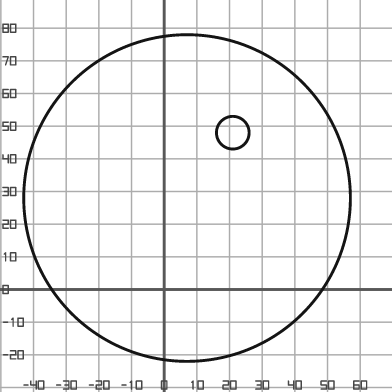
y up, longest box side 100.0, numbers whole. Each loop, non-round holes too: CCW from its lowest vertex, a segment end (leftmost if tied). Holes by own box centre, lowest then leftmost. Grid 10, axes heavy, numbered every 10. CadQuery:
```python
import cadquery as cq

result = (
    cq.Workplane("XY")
    .moveTo(7.0, 28.0)
    .circle(50.0)
    .moveTo(21.0, 48.0)
    .circle(5.0)
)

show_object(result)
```